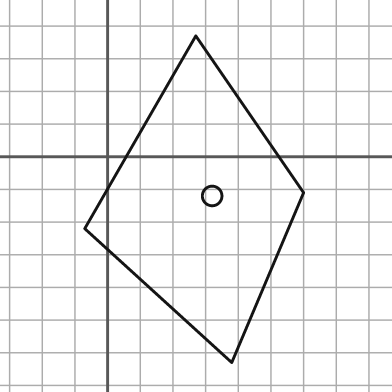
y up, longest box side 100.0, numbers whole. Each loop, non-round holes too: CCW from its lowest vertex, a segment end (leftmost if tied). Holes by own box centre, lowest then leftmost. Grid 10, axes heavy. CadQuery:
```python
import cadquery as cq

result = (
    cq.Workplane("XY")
    .moveTo(38.0, -63.0)
    .lineTo(60.0, -11.0)
    .lineTo(27.0, 37.0)
    .lineTo(-7.0, -22.0)
    .close()
    .moveTo(32.0, -12.0)
    .circle(3.0)
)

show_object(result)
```